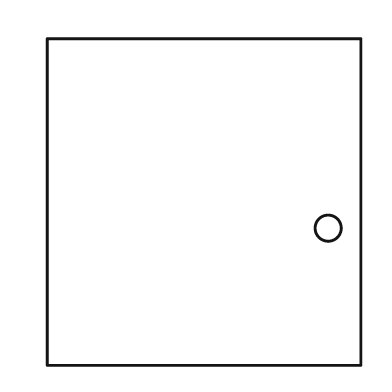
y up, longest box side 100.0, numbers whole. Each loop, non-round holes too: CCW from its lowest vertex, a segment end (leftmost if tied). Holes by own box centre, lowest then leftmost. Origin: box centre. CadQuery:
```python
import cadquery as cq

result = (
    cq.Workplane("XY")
    .moveTo(-48.0, -50.0)
    .lineTo(48.0, -50.0)
    .lineTo(48.0, 50.0)
    .lineTo(-48.0, 50.0)
    .close()
    .moveTo(38.0, -8.0)
    .circle(4.0)
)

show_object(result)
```